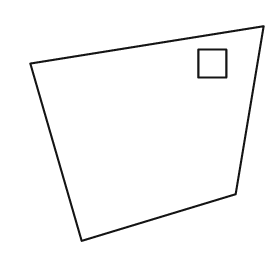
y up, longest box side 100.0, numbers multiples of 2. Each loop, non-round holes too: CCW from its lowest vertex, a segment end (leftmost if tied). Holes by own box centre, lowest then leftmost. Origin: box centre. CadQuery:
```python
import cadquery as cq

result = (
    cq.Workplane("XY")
    .moveTo(-28.0, -46.0)
    .lineTo(38.0, -26.0)
    .lineTo(50.0, 46.0)
    .lineTo(-50.0, 30.0)
    .close()
    .moveTo(22.0, 24.0)
    .lineTo(34.0, 24.0)
    .lineTo(34.0, 36.0)
    .lineTo(22.0, 36.0)
    .close()
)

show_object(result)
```